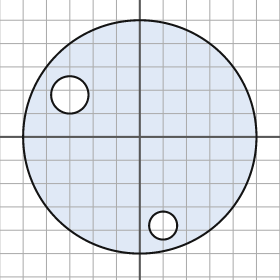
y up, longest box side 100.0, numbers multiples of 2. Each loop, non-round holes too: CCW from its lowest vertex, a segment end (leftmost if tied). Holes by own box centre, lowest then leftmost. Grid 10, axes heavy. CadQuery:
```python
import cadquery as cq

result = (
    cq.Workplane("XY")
    .moveTo(0.0, 0.0)
    .circle(50.0)
    .moveTo(10.0, -38.0)
    .circle(6.0)
    .moveTo(-30.0, 18.0)
    .circle(8.0)
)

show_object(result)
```